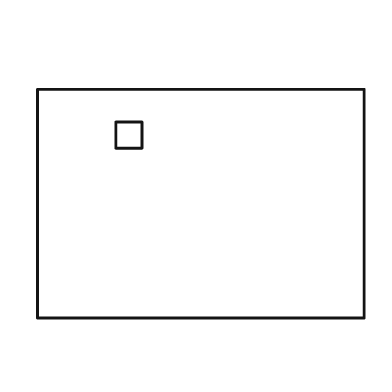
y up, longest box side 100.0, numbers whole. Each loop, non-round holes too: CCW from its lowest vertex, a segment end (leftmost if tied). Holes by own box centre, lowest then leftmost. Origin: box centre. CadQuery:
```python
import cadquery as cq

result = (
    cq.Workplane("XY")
    .moveTo(-50.0, -35.0)
    .lineTo(50.0, -35.0)
    .lineTo(50.0, 35.0)
    .lineTo(-50.0, 35.0)
    .close()
    .moveTo(-26.0, 17.0)
    .lineTo(-18.0, 17.0)
    .lineTo(-18.0, 25.0)
    .lineTo(-26.0, 25.0)
    .close()
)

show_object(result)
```